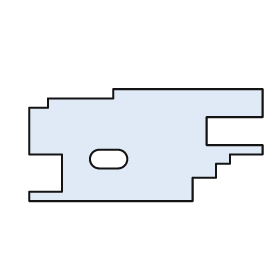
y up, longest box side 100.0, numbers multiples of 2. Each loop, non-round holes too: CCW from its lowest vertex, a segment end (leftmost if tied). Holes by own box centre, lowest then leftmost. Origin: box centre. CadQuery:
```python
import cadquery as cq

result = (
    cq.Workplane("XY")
    .moveTo(-50.0, -24.0)
    .lineTo(20.0, -24.0)
    .lineTo(20.0, -14.0)
    .lineTo(30.0, -14.0)
    .lineTo(30.0, -8.0)
    .lineTo(36.0, -8.0)
    .lineTo(36.0, -4.0)
    .lineTo(50.0, -4.0)
    .lineTo(50.0, 0.0)
    .lineTo(26.0, 0.0)
    .lineTo(26.0, 12.0)
    .lineTo(50.0, 12.0)
    .lineTo(50.0, 24.0)
    .lineTo(-14.0, 24.0)
    .lineTo(-14.0, 20.0)
    .lineTo(-42.0, 20.0)
    .lineTo(-42.0, 16.0)
    .lineTo(-50.0, 16.0)
    .lineTo(-50.0, -4.0)
    .lineTo(-36.0, -4.0)
    .lineTo(-36.0, -20.0)
    .lineTo(-50.0, -20.0)
    .close()
    .moveTo(-20.0, -10.0)
    .lineTo(-12.0, -10.0)
    .threePointArc((-8.0, -6.0), (-12.0, -2.0))
    .lineTo(-20.0, -2.0)
    .threePointArc((-24.0, -6.0), (-20.0, -10.0))
    .close()
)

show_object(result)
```